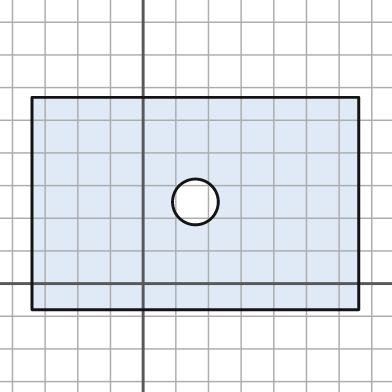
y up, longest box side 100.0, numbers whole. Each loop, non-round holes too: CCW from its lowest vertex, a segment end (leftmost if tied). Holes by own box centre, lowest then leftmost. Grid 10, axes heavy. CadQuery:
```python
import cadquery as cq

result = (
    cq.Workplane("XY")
    .moveTo(-34.0, -8.0)
    .lineTo(66.0, -8.0)
    .lineTo(66.0, 57.0)
    .lineTo(-34.0, 57.0)
    .close()
    .moveTo(16.0, 25.0)
    .circle(7.0)
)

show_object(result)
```